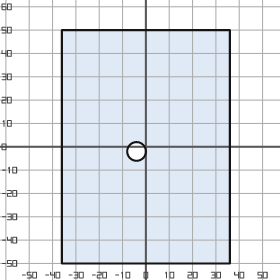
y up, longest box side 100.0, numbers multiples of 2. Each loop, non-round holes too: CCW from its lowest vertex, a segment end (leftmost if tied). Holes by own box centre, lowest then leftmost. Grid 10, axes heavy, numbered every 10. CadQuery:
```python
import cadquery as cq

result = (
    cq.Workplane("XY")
    .moveTo(-36.0, -50.0)
    .lineTo(36.0, -50.0)
    .lineTo(36.0, 50.0)
    .lineTo(-36.0, 50.0)
    .close()
    .moveTo(-4.0, -2.0)
    .circle(4.0)
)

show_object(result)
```